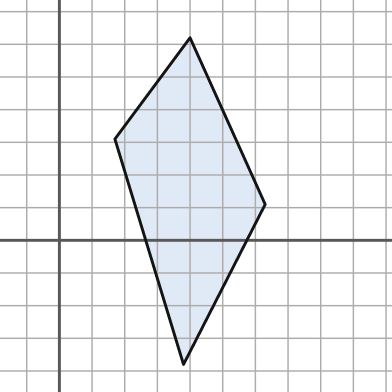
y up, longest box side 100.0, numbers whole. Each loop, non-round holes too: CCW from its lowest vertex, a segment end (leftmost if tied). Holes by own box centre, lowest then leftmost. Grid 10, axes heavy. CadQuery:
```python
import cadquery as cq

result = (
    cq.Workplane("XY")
    .moveTo(38.0, -38.0)
    .lineTo(63.0, 11.0)
    .lineTo(40.0, 62.0)
    .lineTo(17.0, 31.0)
    .close()
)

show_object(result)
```